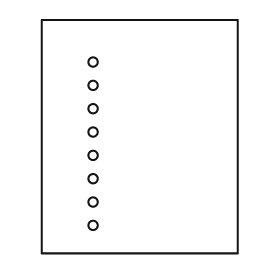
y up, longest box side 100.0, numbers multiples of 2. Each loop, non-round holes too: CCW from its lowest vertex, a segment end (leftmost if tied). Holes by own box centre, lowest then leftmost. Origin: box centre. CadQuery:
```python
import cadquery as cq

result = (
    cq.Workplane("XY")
    .moveTo(-42.0, -50.0)
    .lineTo(42.0, -50.0)
    .lineTo(42.0, 50.0)
    .lineTo(-42.0, 50.0)
    .close()
    .moveTo(-20.0, -38.0)
    .circle(2.0)
    .moveTo(-20.0, -28.0)
    .circle(2.0)
    .moveTo(-20.0, -18.0)
    .circle(2.0)
    .moveTo(-20.0, -8.0)
    .circle(2.0)
    .moveTo(-20.0, 2.0)
    .circle(2.0)
    .moveTo(-20.0, 12.0)
    .circle(2.0)
    .moveTo(-20.0, 22.0)
    .circle(2.0)
    .moveTo(-20.0, 32.0)
    .circle(2.0)
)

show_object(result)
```